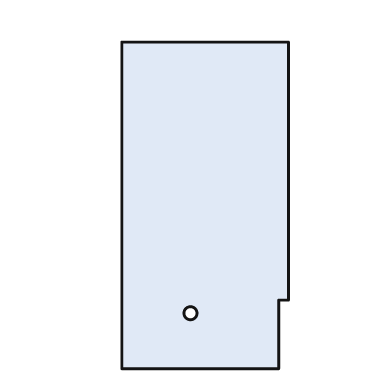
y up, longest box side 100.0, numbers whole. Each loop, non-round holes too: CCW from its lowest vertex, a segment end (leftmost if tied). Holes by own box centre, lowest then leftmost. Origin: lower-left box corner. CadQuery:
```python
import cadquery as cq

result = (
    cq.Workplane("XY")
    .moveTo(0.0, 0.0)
    .lineTo(48.0, 0.0)
    .lineTo(48.0, 21.0)
    .lineTo(51.0, 21.0)
    .lineTo(51.0, 100.0)
    .lineTo(0.0, 100.0)
    .close()
    .moveTo(21.0, 17.0)
    .circle(2.0)
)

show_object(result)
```